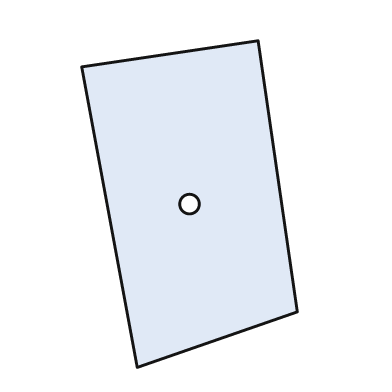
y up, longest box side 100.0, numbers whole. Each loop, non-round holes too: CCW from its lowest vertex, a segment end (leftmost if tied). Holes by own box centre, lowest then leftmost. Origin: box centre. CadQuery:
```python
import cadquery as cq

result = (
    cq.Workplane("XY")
    .moveTo(-16.0, -50.0)
    .lineTo(33.0, -33.0)
    .lineTo(21.0, 50.0)
    .lineTo(-33.0, 42.0)
    .close()
    .moveTo(0.0, 0.0)
    .circle(3.0)
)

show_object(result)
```